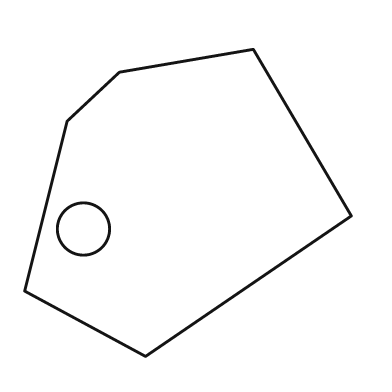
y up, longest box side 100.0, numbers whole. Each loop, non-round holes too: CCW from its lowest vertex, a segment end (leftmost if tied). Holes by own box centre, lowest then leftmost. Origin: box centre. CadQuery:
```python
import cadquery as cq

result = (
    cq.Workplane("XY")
    .moveTo(-13.0, -47.0)
    .lineTo(50.0, -4.0)
    .lineTo(20.0, 47.0)
    .lineTo(-21.0, 40.0)
    .lineTo(-37.0, 25.0)
    .lineTo(-50.0, -27.0)
    .close()
    .moveTo(-32.0, -8.0)
    .circle(8.0)
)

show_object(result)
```